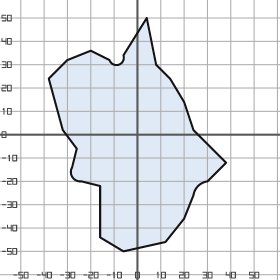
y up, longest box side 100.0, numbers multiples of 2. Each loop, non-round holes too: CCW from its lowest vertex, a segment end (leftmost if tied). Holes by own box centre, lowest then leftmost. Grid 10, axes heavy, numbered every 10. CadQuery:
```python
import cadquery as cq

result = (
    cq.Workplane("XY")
    .moveTo(-6.0, -50.0)
    .lineTo(12.0, -46.0)
    .lineTo(20.0, -36.0)
    .lineTo(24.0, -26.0)
    .threePointArc((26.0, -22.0), (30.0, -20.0))
    .lineTo(38.0, -12.0)
    .lineTo(24.0, 2.0)
    .lineTo(20.0, 14.0)
    .lineTo(14.0, 24.0)
    .lineTo(8.0, 30.0)
    .lineTo(4.0, 50.0)
    .lineTo(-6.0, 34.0)
    .threePointArc((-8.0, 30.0), (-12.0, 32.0))
    .lineTo(-20.0, 36.0)
    .lineTo(-30.0, 32.0)
    .lineTo(-38.0, 24.0)
    .lineTo(-32.0, 2.0)
    .lineTo(-26.0, -6.0)
    .lineTo(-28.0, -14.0)
    .threePointArc((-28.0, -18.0), (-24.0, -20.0))
    .lineTo(-16.0, -22.0)
    .lineTo(-16.0, -44.0)
    .close()
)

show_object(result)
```